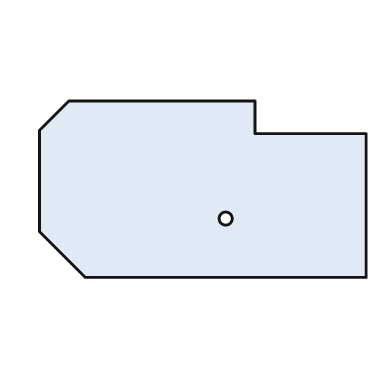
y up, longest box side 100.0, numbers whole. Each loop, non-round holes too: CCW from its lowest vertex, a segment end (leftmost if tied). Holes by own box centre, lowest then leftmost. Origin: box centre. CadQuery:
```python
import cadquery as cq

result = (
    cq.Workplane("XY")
    .moveTo(-36.0, -27.0)
    .lineTo(50.0, -27.0)
    .lineTo(50.0, 17.0)
    .lineTo(16.0, 17.0)
    .lineTo(16.0, 27.0)
    .lineTo(-41.0, 27.0)
    .lineTo(-50.0, 18.0)
    .lineTo(-50.0, -13.0)
    .close()
    .moveTo(7.0, -9.0)
    .circle(2.0)
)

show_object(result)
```